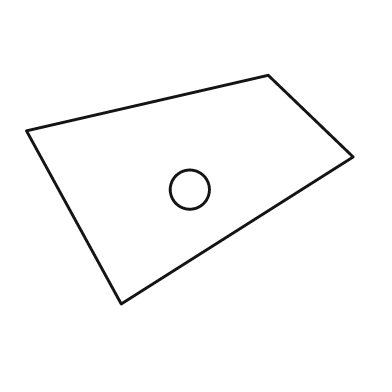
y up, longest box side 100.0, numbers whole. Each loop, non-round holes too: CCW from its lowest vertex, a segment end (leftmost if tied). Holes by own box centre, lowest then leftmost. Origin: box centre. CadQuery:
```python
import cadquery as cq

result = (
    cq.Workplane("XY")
    .moveTo(-21.0, -35.0)
    .lineTo(50.0, 10.0)
    .lineTo(24.0, 35.0)
    .lineTo(-50.0, 18.0)
    .close()
    .moveTo(0.0, 0.0)
    .circle(6.0)
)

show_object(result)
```